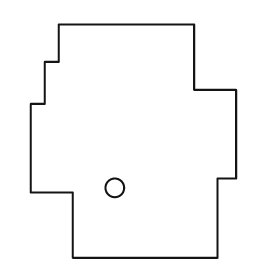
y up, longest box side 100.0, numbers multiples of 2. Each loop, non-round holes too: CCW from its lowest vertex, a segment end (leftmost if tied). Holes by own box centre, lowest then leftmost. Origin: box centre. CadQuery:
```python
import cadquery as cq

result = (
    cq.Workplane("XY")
    .moveTo(-26.0, -50.0)
    .lineTo(36.0, -50.0)
    .lineTo(36.0, -16.0)
    .lineTo(44.0, -16.0)
    .lineTo(44.0, 22.0)
    .lineTo(26.0, 22.0)
    .lineTo(26.0, 50.0)
    .lineTo(-32.0, 50.0)
    .lineTo(-32.0, 34.0)
    .lineTo(-38.0, 34.0)
    .lineTo(-38.0, 16.0)
    .lineTo(-44.0, 16.0)
    .lineTo(-44.0, -22.0)
    .lineTo(-26.0, -22.0)
    .close()
    .moveTo(-8.0, -20.0)
    .circle(4.0)
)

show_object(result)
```